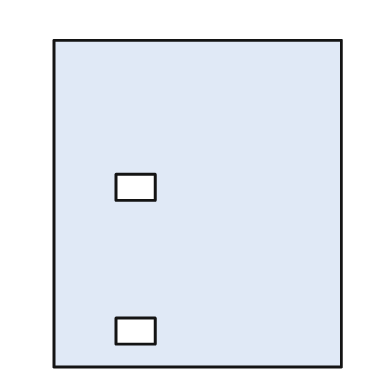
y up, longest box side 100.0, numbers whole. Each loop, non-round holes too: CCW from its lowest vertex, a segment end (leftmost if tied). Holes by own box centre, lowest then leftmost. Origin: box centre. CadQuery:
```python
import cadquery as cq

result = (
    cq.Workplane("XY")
    .moveTo(-44.0, -50.0)
    .lineTo(44.0, -50.0)
    .lineTo(44.0, 50.0)
    .lineTo(-44.0, 50.0)
    .close()
    .moveTo(-25.0, -43.0)
    .lineTo(-13.0, -43.0)
    .lineTo(-13.0, -35.0)
    .lineTo(-25.0, -35.0)
    .close()
    .moveTo(-25.0, 1.0)
    .lineTo(-13.0, 1.0)
    .lineTo(-13.0, 9.0)
    .lineTo(-25.0, 9.0)
    .close()
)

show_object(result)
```